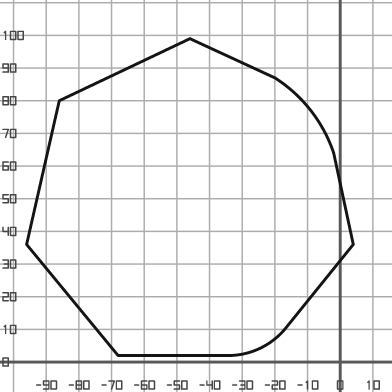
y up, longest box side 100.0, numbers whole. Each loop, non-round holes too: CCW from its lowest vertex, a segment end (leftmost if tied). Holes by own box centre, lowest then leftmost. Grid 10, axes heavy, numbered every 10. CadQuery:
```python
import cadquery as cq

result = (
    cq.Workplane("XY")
    .moveTo(-68.0, 2.0)
    .lineTo(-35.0, 2.0)
    .threePointArc((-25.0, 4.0), (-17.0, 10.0))
    .lineTo(4.0, 36.0)
    .lineTo(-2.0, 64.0)
    .threePointArc((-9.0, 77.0), (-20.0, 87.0))
    .lineTo(-46.0, 99.0)
    .lineTo(-86.0, 80.0)
    .lineTo(-96.0, 36.0)
    .close()
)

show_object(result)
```